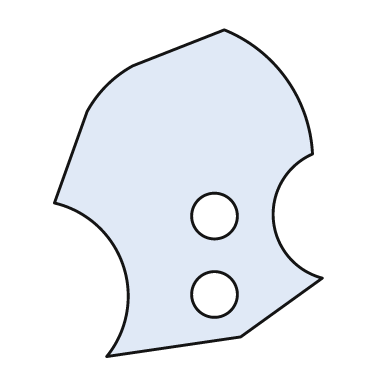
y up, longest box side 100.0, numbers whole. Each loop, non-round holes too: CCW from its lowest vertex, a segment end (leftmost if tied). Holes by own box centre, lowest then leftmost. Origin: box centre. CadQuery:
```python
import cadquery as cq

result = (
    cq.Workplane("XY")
    .moveTo(-25.0, -50.0)
    .lineTo(16.0, -44.0)
    .lineTo(41.0, -26.0)
    .threePointArc((26.0, -8.0), (38.0, 12.0))
    .threePointArc((30.0, 35.0), (11.0, 50.0))
    .lineTo(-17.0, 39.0)
    .threePointArc((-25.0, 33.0), (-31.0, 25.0))
    .lineTo(-41.0, -3.0)
    .threePointArc((-20.0, -22.0), (-25.0, -50.0))
    .close()
    .moveTo(8.0, -31.0)
    .circle(7.0)
    .moveTo(8.0, -7.0)
    .circle(7.0)
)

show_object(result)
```